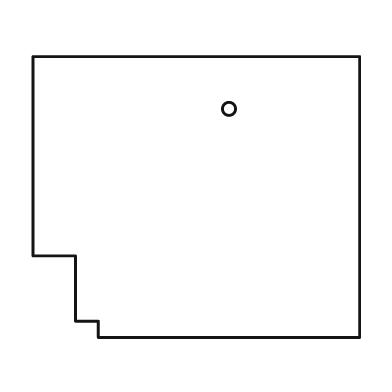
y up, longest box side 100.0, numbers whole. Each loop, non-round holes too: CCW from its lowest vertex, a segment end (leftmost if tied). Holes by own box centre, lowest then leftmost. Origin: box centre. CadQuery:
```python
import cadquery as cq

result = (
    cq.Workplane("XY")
    .moveTo(-30.0, -43.0)
    .lineTo(50.0, -43.0)
    .lineTo(50.0, 43.0)
    .lineTo(-50.0, 43.0)
    .lineTo(-50.0, -18.0)
    .lineTo(-37.0, -18.0)
    .lineTo(-37.0, -38.0)
    .lineTo(-30.0, -38.0)
    .close()
    .moveTo(10.0, 27.0)
    .circle(2.0)
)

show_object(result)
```